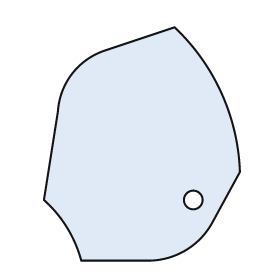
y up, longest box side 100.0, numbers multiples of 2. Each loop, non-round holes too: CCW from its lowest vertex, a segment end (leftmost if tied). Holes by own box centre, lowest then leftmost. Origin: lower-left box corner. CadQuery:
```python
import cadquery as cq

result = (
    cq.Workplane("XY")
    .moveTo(16.0, 0.0)
    .lineTo(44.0, 0.0)
    .threePointArc((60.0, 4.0), (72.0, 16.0))
    .lineTo(84.0, 38.0)
    .threePointArc((76.0, 72.0), (56.0, 100.0))
    .lineTo(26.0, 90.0)
    .threePointArc((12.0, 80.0), (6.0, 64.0))
    .lineTo(0.0, 26.0)
    .threePointArc((10.0, 14.0), (16.0, 0.0))
    .close()
    .moveTo(64.0, 26.0)
    .circle(4.0)
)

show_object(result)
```